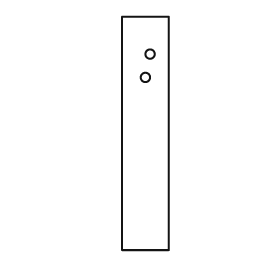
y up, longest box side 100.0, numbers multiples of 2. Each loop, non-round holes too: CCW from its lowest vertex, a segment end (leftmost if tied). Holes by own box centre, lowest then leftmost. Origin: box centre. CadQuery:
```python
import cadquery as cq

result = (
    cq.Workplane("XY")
    .moveTo(-10.0, -50.0)
    .lineTo(10.0, -50.0)
    .lineTo(10.0, 50.0)
    .lineTo(-10.0, 50.0)
    .close()
    .moveTo(0.0, 24.0)
    .circle(2.0)
    .moveTo(2.0, 34.0)
    .circle(2.0)
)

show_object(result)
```